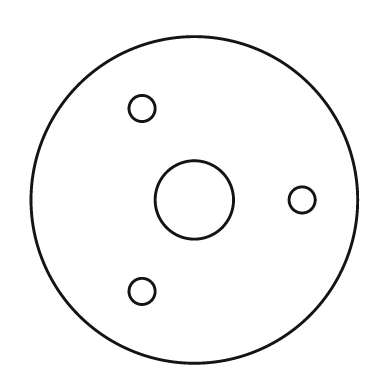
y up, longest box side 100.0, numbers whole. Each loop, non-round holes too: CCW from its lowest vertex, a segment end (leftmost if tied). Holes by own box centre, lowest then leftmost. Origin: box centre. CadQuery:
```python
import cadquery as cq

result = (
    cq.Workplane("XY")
    .moveTo(0.0, 0.0)
    .circle(50.0)
    .moveTo(-16.0, -28.0)
    .circle(4.0)
    .moveTo(0.0, 0.0)
    .circle(12.0)
    .moveTo(33.0, 0.0)
    .circle(4.0)
    .moveTo(-16.0, 28.0)
    .circle(4.0)
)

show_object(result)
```